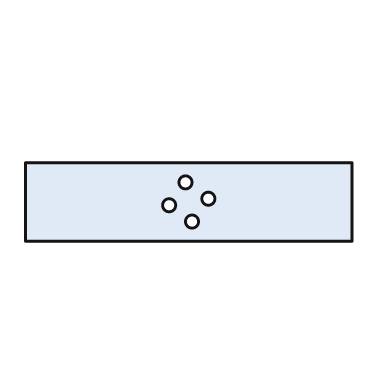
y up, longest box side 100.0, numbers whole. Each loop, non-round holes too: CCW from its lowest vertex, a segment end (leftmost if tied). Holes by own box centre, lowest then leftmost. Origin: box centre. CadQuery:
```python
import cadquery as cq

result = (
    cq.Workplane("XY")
    .moveTo(-50.0, -12.0)
    .lineTo(50.0, -12.0)
    .lineTo(50.0, 12.0)
    .lineTo(-50.0, 12.0)
    .close()
    .moveTo(1.0, -6.0)
    .circle(2.0)
    .moveTo(-6.0, -1.0)
    .circle(2.0)
    .moveTo(6.0, 1.0)
    .circle(2.0)
    .moveTo(-1.0, 6.0)
    .circle(2.0)
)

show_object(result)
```